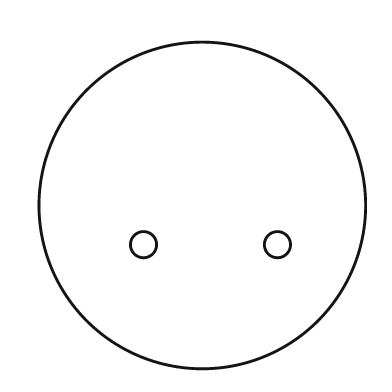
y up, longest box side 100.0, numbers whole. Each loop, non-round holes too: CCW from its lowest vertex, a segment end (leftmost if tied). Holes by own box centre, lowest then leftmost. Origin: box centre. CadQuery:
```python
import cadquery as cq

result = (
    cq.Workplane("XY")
    .moveTo(0.0, 0.0)
    .circle(50.0)
    .moveTo(-18.0, -12.0)
    .circle(4.0)
    .moveTo(23.0, -12.0)
    .circle(4.0)
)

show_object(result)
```